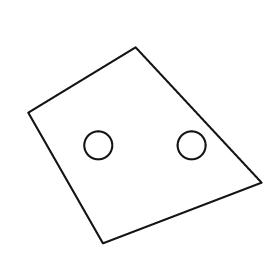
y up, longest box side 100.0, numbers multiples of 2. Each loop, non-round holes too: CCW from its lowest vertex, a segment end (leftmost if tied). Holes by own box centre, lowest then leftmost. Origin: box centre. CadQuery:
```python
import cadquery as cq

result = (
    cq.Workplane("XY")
    .moveTo(-18.0, -42.0)
    .lineTo(50.0, -16.0)
    .lineTo(-4.0, 42.0)
    .lineTo(-50.0, 14.0)
    .close()
    .moveTo(-20.0, 0.0)
    .circle(6.0)
    .moveTo(20.0, 0.0)
    .circle(6.0)
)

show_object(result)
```